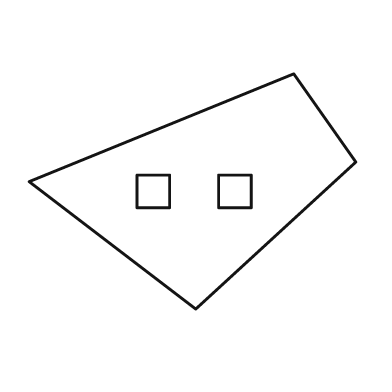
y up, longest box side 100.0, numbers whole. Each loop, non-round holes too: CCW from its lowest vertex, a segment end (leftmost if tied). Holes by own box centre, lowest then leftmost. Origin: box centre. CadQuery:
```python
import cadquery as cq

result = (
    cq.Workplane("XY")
    .moveTo(1.0, -36.0)
    .lineTo(50.0, 9.0)
    .lineTo(31.0, 36.0)
    .lineTo(-50.0, 3.0)
    .close()
    .moveTo(-17.0, -5.0)
    .lineTo(-7.0, -5.0)
    .lineTo(-7.0, 5.0)
    .lineTo(-17.0, 5.0)
    .close()
    .moveTo(8.0, -5.0)
    .lineTo(18.0, -5.0)
    .lineTo(18.0, 5.0)
    .lineTo(8.0, 5.0)
    .close()
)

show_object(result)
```